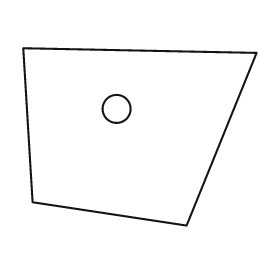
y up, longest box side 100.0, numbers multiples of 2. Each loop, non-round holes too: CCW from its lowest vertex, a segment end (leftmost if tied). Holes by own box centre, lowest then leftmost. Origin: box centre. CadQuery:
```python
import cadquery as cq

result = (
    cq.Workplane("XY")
    .moveTo(20.0, -38.0)
    .lineTo(50.0, 36.0)
    .lineTo(-50.0, 38.0)
    .lineTo(-46.0, -28.0)
    .close()
    .moveTo(-10.0, 12.0)
    .circle(6.0)
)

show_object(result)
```